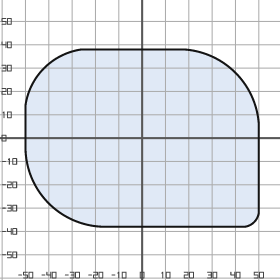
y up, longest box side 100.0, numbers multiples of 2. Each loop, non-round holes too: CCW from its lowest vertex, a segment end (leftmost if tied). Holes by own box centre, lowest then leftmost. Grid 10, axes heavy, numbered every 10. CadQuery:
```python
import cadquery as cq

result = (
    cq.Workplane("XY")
    .moveTo(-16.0, -38.0)
    .lineTo(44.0, -38.0)
    .threePointArc((48.0, -36.0), (50.0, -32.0))
    .lineTo(50.0, 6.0)
    .threePointArc((40.0, 28.0), (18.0, 38.0))
    .lineTo(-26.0, 38.0)
    .threePointArc((-42.0, 30.0), (-50.0, 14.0))
    .lineTo(-50.0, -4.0)
    .threePointArc((-40.0, -28.0), (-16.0, -38.0))
    .close()
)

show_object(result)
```